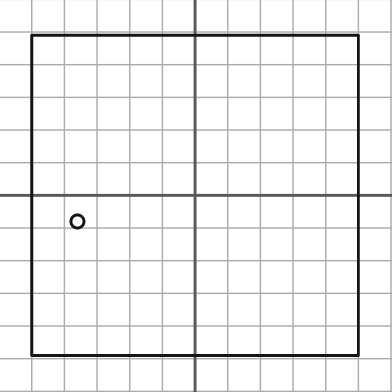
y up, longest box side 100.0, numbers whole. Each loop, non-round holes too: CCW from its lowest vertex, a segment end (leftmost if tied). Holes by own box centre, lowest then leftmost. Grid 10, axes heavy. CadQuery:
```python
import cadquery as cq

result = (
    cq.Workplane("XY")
    .moveTo(-50.0, -49.0)
    .lineTo(50.0, -49.0)
    .lineTo(50.0, 49.0)
    .lineTo(-50.0, 49.0)
    .close()
    .moveTo(-36.0, -8.0)
    .circle(2.0)
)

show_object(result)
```